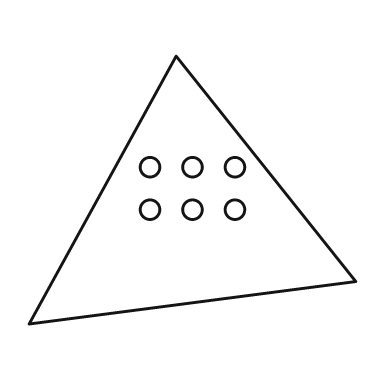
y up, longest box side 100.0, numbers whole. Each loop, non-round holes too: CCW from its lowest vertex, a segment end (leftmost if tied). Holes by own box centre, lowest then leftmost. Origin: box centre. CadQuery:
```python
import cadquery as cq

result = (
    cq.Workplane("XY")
    .moveTo(-50.0, -41.0)
    .lineTo(50.0, -28.0)
    .lineTo(-5.0, 41.0)
    .close()
    .moveTo(-13.0, -6.0)
    .circle(3.0)
    .moveTo(0.0, -6.0)
    .circle(3.0)
    .moveTo(13.0, -6.0)
    .circle(3.0)
    .moveTo(-13.0, 7.0)
    .circle(3.0)
    .moveTo(0.0, 7.0)
    .circle(3.0)
    .moveTo(13.0, 7.0)
    .circle(3.0)
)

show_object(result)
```